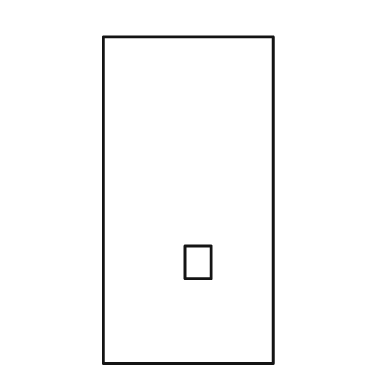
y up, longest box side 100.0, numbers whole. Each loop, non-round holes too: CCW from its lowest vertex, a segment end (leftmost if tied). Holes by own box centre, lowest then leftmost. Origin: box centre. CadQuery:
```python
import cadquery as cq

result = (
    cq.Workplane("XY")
    .moveTo(-26.0, -50.0)
    .lineTo(26.0, -50.0)
    .lineTo(26.0, 50.0)
    .lineTo(-26.0, 50.0)
    .close()
    .moveTo(-1.0, -24.0)
    .lineTo(7.0, -24.0)
    .lineTo(7.0, -14.0)
    .lineTo(-1.0, -14.0)
    .close()
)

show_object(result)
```